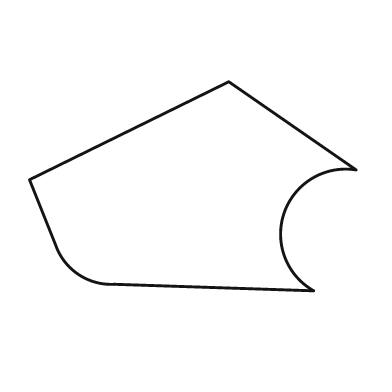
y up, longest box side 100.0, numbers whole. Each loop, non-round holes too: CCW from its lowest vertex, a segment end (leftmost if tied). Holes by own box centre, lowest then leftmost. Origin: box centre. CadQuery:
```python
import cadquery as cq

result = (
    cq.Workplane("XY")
    .moveTo(37.0, -32.0)
    .threePointArc((28.0, -8.0), (50.0, 5.0))
    .lineTo(11.0, 32.0)
    .lineTo(-50.0, 2.0)
    .lineTo(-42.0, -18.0)
    .threePointArc((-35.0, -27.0), (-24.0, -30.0))
    .close()
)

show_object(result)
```